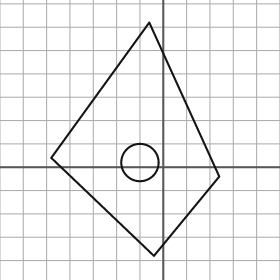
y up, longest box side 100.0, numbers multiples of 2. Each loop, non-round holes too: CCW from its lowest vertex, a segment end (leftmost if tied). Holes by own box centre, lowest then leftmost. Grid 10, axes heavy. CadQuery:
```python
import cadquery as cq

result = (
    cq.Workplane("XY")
    .moveTo(-4.0, -38.0)
    .lineTo(24.0, -4.0)
    .lineTo(-6.0, 62.0)
    .lineTo(-48.0, 4.0)
    .close()
    .moveTo(-10.0, 2.0)
    .circle(8.0)
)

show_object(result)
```